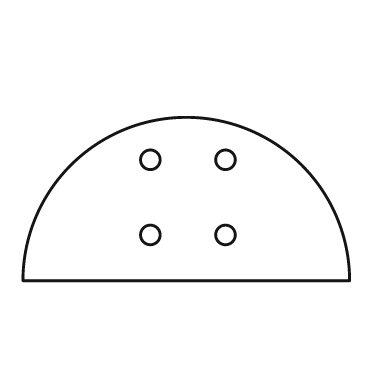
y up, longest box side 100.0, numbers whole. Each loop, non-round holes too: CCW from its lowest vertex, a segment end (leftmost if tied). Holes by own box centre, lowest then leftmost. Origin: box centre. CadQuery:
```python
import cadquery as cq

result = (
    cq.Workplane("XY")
    .moveTo(-50.0, -25.0)
    .lineTo(50.0, -25.0)
    .threePointArc((0.0, 25.0), (-50.0, -25.0))
    .close()
    .moveTo(-11.0, -11.0)
    .circle(3.0)
    .moveTo(12.0, -11.0)
    .circle(3.0)
    .moveTo(-11.0, 12.0)
    .circle(3.0)
    .moveTo(12.0, 12.0)
    .circle(3.0)
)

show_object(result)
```